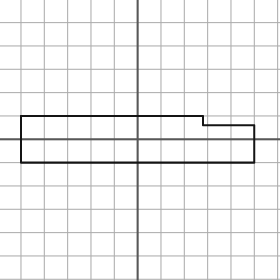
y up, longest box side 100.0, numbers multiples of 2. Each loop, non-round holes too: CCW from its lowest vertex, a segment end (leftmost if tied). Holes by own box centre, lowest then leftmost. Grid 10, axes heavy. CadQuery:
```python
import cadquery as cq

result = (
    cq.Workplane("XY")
    .moveTo(-50.0, -10.0)
    .lineTo(50.0, -10.0)
    .lineTo(50.0, 6.0)
    .lineTo(28.0, 6.0)
    .lineTo(28.0, 10.0)
    .lineTo(-50.0, 10.0)
    .close()
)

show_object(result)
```